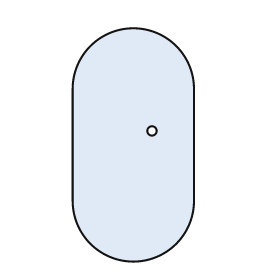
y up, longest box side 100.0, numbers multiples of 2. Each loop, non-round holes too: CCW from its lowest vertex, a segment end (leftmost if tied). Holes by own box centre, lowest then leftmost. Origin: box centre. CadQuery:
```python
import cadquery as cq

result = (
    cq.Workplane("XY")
    .moveTo(-26.0, -24.0)
    .threePointArc((0.0, -50.0), (26.0, -24.0))
    .lineTo(26.0, 24.0)
    .threePointArc((0.0, 50.0), (-26.0, 24.0))
    .close()
    .moveTo(8.0, 6.0)
    .circle(2.0)
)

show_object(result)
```